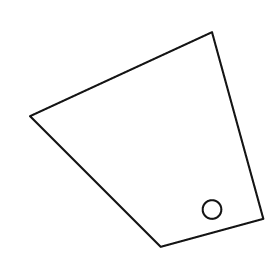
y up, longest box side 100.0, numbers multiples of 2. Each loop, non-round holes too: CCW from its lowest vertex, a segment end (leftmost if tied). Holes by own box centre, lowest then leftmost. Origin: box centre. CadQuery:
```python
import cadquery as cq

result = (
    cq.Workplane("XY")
    .moveTo(6.0, -46.0)
    .lineTo(50.0, -34.0)
    .lineTo(28.0, 46.0)
    .lineTo(-50.0, 10.0)
    .close()
    .moveTo(28.0, -30.0)
    .circle(4.0)
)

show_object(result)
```